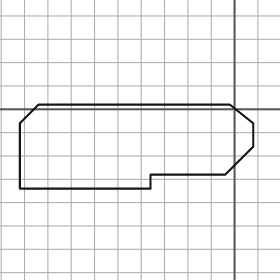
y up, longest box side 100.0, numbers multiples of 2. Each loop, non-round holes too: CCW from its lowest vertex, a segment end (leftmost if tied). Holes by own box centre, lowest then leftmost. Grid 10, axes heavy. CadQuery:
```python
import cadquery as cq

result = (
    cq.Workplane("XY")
    .moveTo(-92.0, -34.0)
    .lineTo(-36.0, -34.0)
    .lineTo(-36.0, -28.0)
    .lineTo(-4.0, -28.0)
    .lineTo(8.0, -16.0)
    .lineTo(8.0, -6.0)
    .lineTo(-2.0, 2.0)
    .lineTo(-84.0, 2.0)
    .lineTo(-92.0, -6.0)
    .close()
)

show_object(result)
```